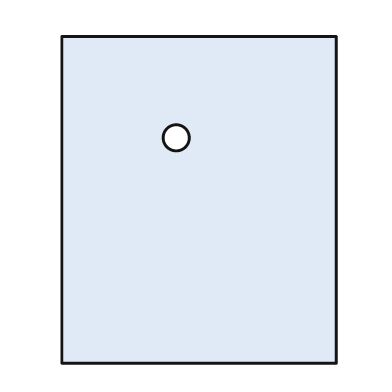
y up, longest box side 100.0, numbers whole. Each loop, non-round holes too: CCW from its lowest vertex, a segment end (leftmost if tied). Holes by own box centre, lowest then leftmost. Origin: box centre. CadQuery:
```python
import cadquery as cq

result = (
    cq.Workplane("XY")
    .moveTo(-42.0, -50.0)
    .lineTo(42.0, -50.0)
    .lineTo(42.0, 50.0)
    .lineTo(-42.0, 50.0)
    .close()
    .moveTo(-7.0, 19.0)
    .circle(4.0)
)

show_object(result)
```